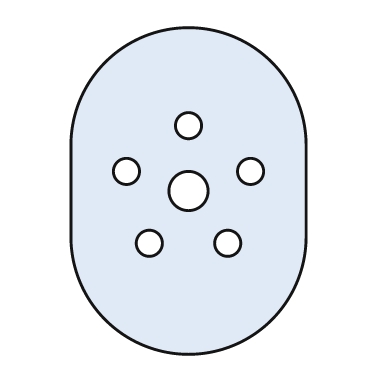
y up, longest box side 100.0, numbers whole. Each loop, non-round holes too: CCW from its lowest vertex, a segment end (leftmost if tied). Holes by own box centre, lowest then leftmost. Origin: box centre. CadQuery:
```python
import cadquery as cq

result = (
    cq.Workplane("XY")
    .moveTo(-36.0, -14.0)
    .threePointArc((0.0, -50.0), (36.0, -14.0))
    .lineTo(36.0, 14.0)
    .threePointArc((0.0, 50.0), (-36.0, 14.0))
    .close()
    .moveTo(-12.0, -16.0)
    .circle(4.0)
    .moveTo(12.0, -16.0)
    .circle(4.0)
    .moveTo(0.0, 0.0)
    .circle(6.0)
    .moveTo(-19.0, 6.0)
    .circle(4.0)
    .moveTo(19.0, 6.0)
    .circle(4.0)
    .moveTo(0.0, 20.0)
    .circle(4.0)
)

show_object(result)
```